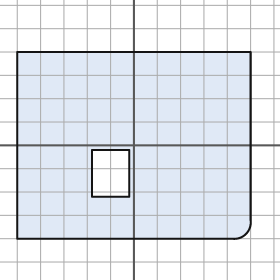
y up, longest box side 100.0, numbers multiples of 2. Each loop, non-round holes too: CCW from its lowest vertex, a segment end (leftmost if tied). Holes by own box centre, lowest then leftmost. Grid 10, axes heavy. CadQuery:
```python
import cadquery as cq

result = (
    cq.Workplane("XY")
    .moveTo(-50.0, -40.0)
    .lineTo(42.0, -40.0)
    .threePointArc((48.0, -38.0), (50.0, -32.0))
    .lineTo(50.0, 40.0)
    .lineTo(-50.0, 40.0)
    .close()
    .moveTo(-18.0, -22.0)
    .lineTo(-2.0, -22.0)
    .lineTo(-2.0, -2.0)
    .lineTo(-18.0, -2.0)
    .close()
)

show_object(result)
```